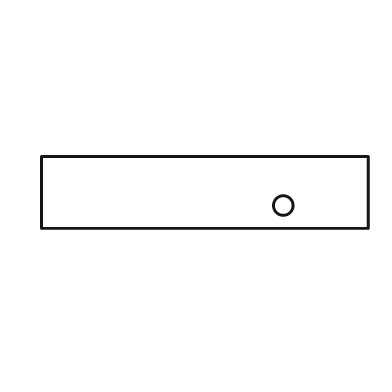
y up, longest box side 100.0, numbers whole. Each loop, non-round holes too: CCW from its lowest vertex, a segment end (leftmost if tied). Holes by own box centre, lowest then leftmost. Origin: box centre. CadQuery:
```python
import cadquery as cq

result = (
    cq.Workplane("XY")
    .moveTo(-50.0, -11.0)
    .lineTo(50.0, -11.0)
    .lineTo(50.0, 11.0)
    .lineTo(-50.0, 11.0)
    .close()
    .moveTo(24.0, -4.0)
    .circle(3.0)
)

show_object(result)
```